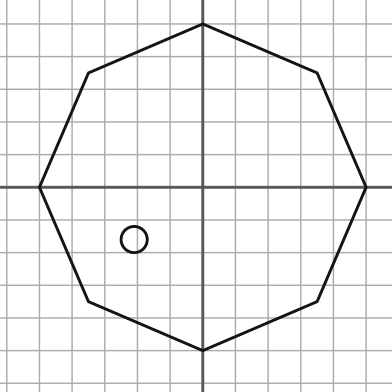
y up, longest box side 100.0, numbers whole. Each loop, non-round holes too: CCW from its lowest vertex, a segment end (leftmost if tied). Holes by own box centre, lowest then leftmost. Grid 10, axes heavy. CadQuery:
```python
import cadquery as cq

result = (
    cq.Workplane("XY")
    .moveTo(0.0, -50.0)
    .lineTo(35.0, -35.0)
    .lineTo(50.0, 0.0)
    .lineTo(35.0, 35.0)
    .lineTo(0.0, 50.0)
    .lineTo(-35.0, 35.0)
    .lineTo(-50.0, 0.0)
    .lineTo(-35.0, -35.0)
    .close()
    .moveTo(-21.0, -16.0)
    .circle(4.0)
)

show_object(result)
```